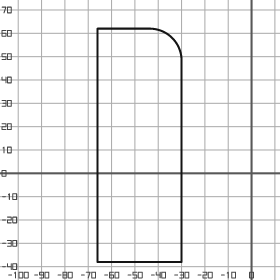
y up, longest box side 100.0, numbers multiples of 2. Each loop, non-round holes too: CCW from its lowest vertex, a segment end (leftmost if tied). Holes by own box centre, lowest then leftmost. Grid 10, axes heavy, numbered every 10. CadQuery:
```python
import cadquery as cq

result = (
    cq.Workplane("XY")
    .moveTo(-66.0, -38.0)
    .lineTo(-30.0, -38.0)
    .lineTo(-30.0, 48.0)
    .threePointArc((-34.0, 58.0), (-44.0, 62.0))
    .lineTo(-66.0, 62.0)
    .close()
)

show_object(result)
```